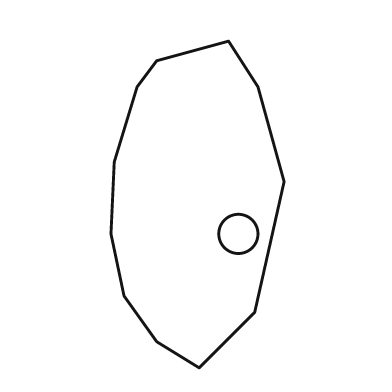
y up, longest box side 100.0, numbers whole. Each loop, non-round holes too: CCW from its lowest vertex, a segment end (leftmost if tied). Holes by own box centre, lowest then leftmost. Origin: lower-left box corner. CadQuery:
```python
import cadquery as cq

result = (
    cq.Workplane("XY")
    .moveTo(27.0, 0.0)
    .lineTo(44.0, 17.0)
    .lineTo(53.0, 57.0)
    .lineTo(45.0, 86.0)
    .lineTo(36.0, 100.0)
    .lineTo(14.0, 94.0)
    .lineTo(8.0, 86.0)
    .lineTo(1.0, 63.0)
    .lineTo(0.0, 41.0)
    .lineTo(4.0, 22.0)
    .lineTo(14.0, 8.0)
    .close()
    .moveTo(39.0, 41.0)
    .circle(6.0)
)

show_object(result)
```